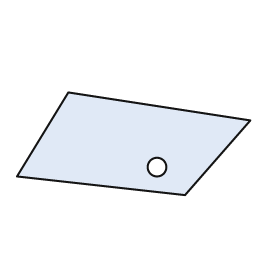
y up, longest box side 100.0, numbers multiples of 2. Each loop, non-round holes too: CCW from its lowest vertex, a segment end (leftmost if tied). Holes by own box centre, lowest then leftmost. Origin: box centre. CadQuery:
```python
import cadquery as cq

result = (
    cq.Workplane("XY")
    .moveTo(22.0, -22.0)
    .lineTo(50.0, 10.0)
    .lineTo(-28.0, 22.0)
    .lineTo(-50.0, -14.0)
    .close()
    .moveTo(10.0, -10.0)
    .circle(4.0)
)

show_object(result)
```